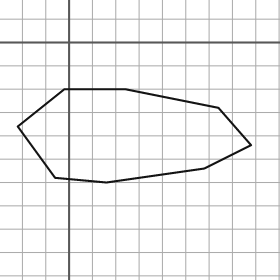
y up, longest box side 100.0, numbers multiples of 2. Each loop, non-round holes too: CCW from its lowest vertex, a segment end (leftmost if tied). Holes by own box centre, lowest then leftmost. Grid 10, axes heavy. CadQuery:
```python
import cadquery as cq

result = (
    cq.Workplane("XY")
    .moveTo(16.0, -60.0)
    .lineTo(58.0, -54.0)
    .lineTo(78.0, -44.0)
    .lineTo(64.0, -28.0)
    .lineTo(24.0, -20.0)
    .lineTo(-2.0, -20.0)
    .lineTo(-22.0, -36.0)
    .lineTo(-6.0, -58.0)
    .close()
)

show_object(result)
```